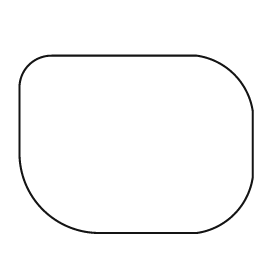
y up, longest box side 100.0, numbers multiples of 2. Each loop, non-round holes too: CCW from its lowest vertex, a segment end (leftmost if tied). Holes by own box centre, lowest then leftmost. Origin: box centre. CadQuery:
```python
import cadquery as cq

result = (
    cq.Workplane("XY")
    .moveTo(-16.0, -38.0)
    .lineTo(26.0, -38.0)
    .threePointArc((42.0, -30.0), (50.0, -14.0))
    .lineTo(50.0, 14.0)
    .threePointArc((42.0, 30.0), (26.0, 38.0))
    .lineTo(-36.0, 38.0)
    .threePointArc((-46.0, 34.0), (-50.0, 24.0))
    .lineTo(-50.0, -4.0)
    .threePointArc((-40.0, -28.0), (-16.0, -38.0))
    .close()
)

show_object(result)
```